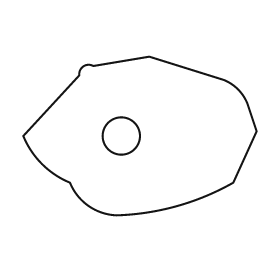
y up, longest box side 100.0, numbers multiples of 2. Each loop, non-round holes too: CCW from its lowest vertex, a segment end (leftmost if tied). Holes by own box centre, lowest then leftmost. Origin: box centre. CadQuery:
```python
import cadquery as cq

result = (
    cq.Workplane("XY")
    .moveTo(-10.0, -34.0)
    .threePointArc((16.0, -30.0), (40.0, -20.0))
    .lineTo(50.0, 2.0)
    .lineTo(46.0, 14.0)
    .threePointArc((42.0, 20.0), (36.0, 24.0))
    .lineTo(4.0, 34.0)
    .lineTo(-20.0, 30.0)
    .threePointArc((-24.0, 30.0), (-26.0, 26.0))
    .lineTo(-50.0, 0.0)
    .threePointArc((-42.0, -12.0), (-30.0, -20.0))
    .threePointArc((-22.0, -30.0), (-10.0, -34.0))
    .close()
    .moveTo(-8.0, 0.0)
    .circle(8.0)
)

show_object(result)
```